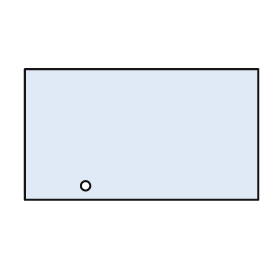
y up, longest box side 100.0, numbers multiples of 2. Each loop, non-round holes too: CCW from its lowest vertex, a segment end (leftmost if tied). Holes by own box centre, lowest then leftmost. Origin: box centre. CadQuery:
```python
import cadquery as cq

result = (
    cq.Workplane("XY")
    .moveTo(-50.0, -28.0)
    .lineTo(50.0, -28.0)
    .lineTo(50.0, 28.0)
    .lineTo(-50.0, 28.0)
    .close()
    .moveTo(-24.0, -22.0)
    .circle(2.0)
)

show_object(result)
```